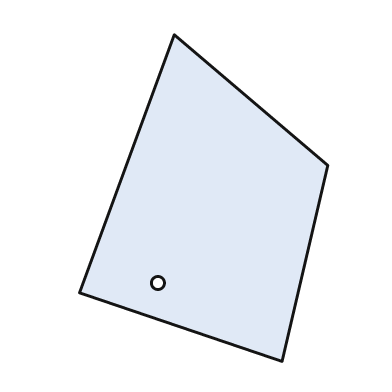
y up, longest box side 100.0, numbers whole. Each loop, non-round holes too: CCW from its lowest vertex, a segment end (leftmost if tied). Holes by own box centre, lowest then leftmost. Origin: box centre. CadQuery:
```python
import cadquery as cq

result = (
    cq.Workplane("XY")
    .moveTo(24.0, -50.0)
    .lineTo(38.0, 10.0)
    .lineTo(-9.0, 50.0)
    .lineTo(-38.0, -29.0)
    .close()
    .moveTo(-14.0, -26.0)
    .circle(2.0)
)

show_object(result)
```